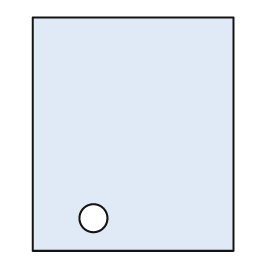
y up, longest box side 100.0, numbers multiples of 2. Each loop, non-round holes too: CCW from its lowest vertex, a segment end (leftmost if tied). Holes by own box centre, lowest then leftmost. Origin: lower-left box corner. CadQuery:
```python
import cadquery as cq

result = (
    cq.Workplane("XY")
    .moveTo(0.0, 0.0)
    .lineTo(86.0, 0.0)
    .lineTo(86.0, 100.0)
    .lineTo(0.0, 100.0)
    .close()
    .moveTo(26.0, 14.0)
    .circle(6.0)
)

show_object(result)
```